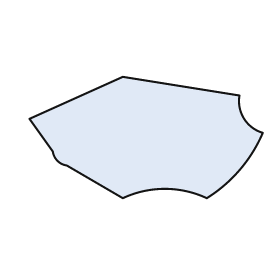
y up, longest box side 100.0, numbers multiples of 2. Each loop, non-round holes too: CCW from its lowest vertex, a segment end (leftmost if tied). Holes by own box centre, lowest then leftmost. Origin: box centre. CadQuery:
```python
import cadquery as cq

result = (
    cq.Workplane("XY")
    .moveTo(-10.0, -26.0)
    .threePointArc((8.0, -22.0), (26.0, -26.0))
    .threePointArc((40.0, -14.0), (50.0, 2.0))
    .threePointArc((42.0, 8.0), (40.0, 18.0))
    .lineTo(-10.0, 26.0)
    .lineTo(-50.0, 8.0)
    .lineTo(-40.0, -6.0)
    .threePointArc((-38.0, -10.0), (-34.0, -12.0))
    .close()
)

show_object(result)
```